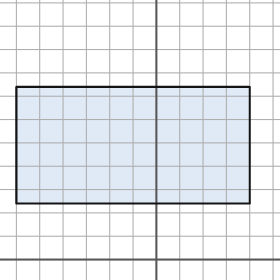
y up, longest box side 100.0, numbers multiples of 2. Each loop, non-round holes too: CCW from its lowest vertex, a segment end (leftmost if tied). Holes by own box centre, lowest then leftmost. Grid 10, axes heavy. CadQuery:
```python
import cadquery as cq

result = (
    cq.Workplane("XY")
    .moveTo(-60.0, 24.0)
    .lineTo(40.0, 24.0)
    .lineTo(40.0, 74.0)
    .lineTo(-60.0, 74.0)
    .close()
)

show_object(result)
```